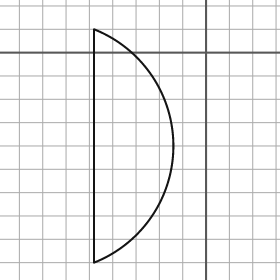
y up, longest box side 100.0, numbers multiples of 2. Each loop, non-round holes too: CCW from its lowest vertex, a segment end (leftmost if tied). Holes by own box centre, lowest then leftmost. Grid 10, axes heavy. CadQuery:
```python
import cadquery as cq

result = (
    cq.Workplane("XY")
    .moveTo(-48.0, -90.0)
    .threePointArc((-14.0, -40.0), (-48.0, 10.0))
    .close()
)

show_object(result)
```